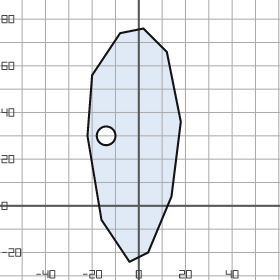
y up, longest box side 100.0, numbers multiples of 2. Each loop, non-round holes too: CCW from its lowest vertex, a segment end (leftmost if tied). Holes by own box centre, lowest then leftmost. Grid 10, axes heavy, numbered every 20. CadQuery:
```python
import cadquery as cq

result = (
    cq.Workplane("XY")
    .moveTo(-4.0, -24.0)
    .lineTo(4.0, -20.0)
    .lineTo(14.0, 4.0)
    .lineTo(18.0, 36.0)
    .lineTo(12.0, 66.0)
    .lineTo(2.0, 76.0)
    .lineTo(-8.0, 74.0)
    .lineTo(-20.0, 56.0)
    .lineTo(-22.0, 30.0)
    .lineTo(-16.0, -6.0)
    .close()
    .moveTo(-14.0, 30.0)
    .circle(4.0)
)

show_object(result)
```